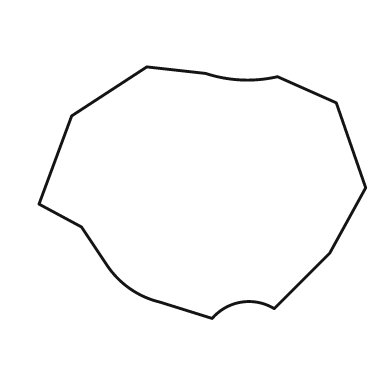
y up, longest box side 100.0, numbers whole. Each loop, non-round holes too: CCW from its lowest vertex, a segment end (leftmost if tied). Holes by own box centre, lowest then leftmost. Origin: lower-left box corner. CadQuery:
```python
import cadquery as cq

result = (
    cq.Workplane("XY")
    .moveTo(53.0, 0.0)
    .threePointArc((62.0, 5.0), (72.0, 3.0))
    .lineTo(89.0, 20.0)
    .lineTo(100.0, 40.0)
    .lineTo(91.0, 66.0)
    .lineTo(73.0, 74.0)
    .threePointArc((62.0, 73.0), (51.0, 75.0))
    .lineTo(33.0, 77.0)
    .lineTo(10.0, 62.0)
    .lineTo(0.0, 35.0)
    .lineTo(13.0, 28.0)
    .lineTo(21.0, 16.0)
    .threePointArc((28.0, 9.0), (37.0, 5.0))
    .close()
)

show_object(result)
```